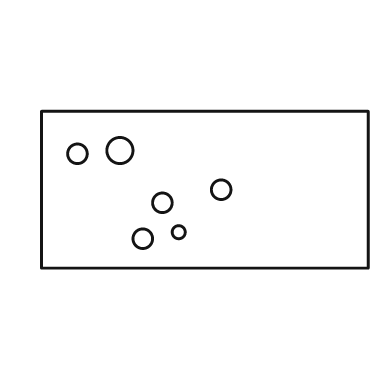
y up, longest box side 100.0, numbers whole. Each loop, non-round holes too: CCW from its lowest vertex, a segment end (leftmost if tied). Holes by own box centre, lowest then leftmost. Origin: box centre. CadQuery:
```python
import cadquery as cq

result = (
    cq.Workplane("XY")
    .moveTo(-50.0, -24.0)
    .lineTo(50.0, -24.0)
    .lineTo(50.0, 24.0)
    .lineTo(-50.0, 24.0)
    .close()
    .moveTo(-19.0, -15.0)
    .circle(3.0)
    .moveTo(-8.0, -13.0)
    .circle(2.0)
    .moveTo(-13.0, -4.0)
    .circle(3.0)
    .moveTo(5.0, 0.0)
    .circle(3.0)
    .moveTo(-39.0, 11.0)
    .circle(3.0)
    .moveTo(-26.0, 12.0)
    .circle(4.0)
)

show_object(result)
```